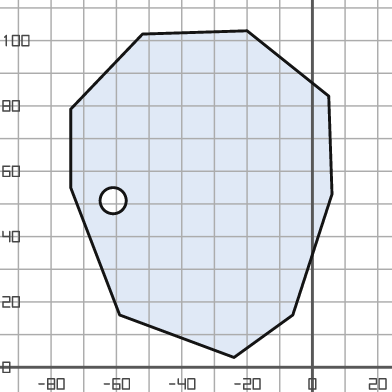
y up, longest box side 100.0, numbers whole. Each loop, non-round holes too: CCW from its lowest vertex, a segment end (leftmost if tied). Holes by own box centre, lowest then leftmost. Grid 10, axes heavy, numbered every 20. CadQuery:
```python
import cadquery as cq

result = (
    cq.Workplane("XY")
    .moveTo(-24.0, 3.0)
    .lineTo(-6.0, 16.0)
    .lineTo(6.0, 53.0)
    .lineTo(5.0, 83.0)
    .lineTo(-20.0, 103.0)
    .lineTo(-52.0, 102.0)
    .lineTo(-74.0, 79.0)
    .lineTo(-74.0, 55.0)
    .lineTo(-59.0, 16.0)
    .close()
    .moveTo(-61.0, 51.0)
    .circle(4.0)
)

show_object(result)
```